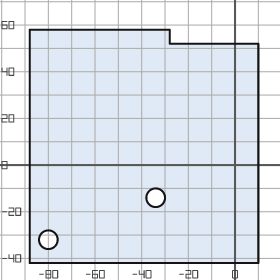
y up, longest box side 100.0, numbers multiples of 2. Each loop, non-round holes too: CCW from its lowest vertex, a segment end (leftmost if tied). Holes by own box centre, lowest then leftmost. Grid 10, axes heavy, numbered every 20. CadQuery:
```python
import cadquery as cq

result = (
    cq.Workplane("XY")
    .moveTo(-88.0, -42.0)
    .lineTo(10.0, -42.0)
    .lineTo(10.0, 52.0)
    .lineTo(-28.0, 52.0)
    .lineTo(-28.0, 58.0)
    .lineTo(-88.0, 58.0)
    .close()
    .moveTo(-80.0, -32.0)
    .circle(4.0)
    .moveTo(-34.0, -14.0)
    .circle(4.0)
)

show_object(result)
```